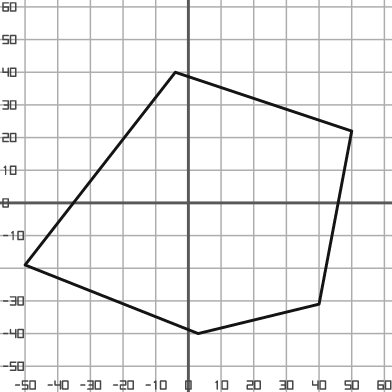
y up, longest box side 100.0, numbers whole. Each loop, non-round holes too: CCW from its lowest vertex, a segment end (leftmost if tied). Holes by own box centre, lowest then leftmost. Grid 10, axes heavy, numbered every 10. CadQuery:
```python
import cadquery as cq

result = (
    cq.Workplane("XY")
    .moveTo(3.0, -40.0)
    .lineTo(40.0, -31.0)
    .lineTo(50.0, 22.0)
    .lineTo(-4.0, 40.0)
    .lineTo(-50.0, -19.0)
    .close()
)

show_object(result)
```